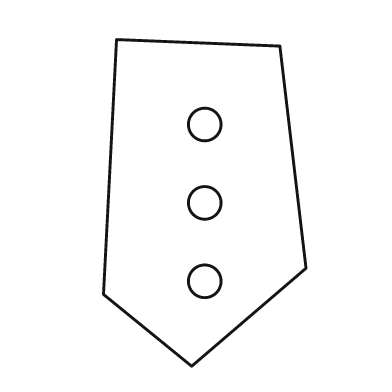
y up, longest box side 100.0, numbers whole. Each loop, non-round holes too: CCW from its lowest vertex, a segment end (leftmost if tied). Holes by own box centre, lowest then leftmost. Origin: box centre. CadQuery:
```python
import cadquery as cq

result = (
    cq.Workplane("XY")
    .moveTo(-4.0, -50.0)
    .lineTo(31.0, -20.0)
    .lineTo(23.0, 48.0)
    .lineTo(-27.0, 50.0)
    .lineTo(-31.0, -28.0)
    .close()
    .moveTo(0.0, -24.0)
    .circle(5.0)
    .moveTo(0.0, 0.0)
    .circle(5.0)
    .moveTo(0.0, 24.0)
    .circle(5.0)
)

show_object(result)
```